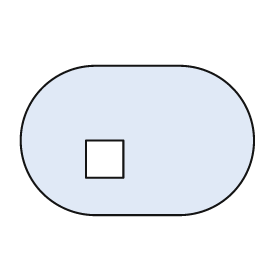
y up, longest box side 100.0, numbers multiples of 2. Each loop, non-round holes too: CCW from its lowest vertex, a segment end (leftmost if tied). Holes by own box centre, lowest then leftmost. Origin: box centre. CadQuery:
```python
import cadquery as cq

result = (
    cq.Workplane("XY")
    .moveTo(-18.0, -32.0)
    .lineTo(18.0, -32.0)
    .threePointArc((50.0, 0.0), (18.0, 32.0))
    .lineTo(-18.0, 32.0)
    .threePointArc((-50.0, 0.0), (-18.0, -32.0))
    .close()
    .moveTo(-22.0, -16.0)
    .lineTo(-6.0, -16.0)
    .lineTo(-6.0, 0.0)
    .lineTo(-22.0, 0.0)
    .close()
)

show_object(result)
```